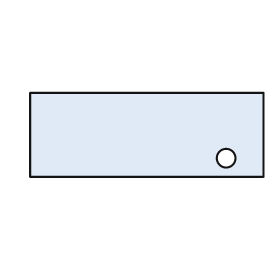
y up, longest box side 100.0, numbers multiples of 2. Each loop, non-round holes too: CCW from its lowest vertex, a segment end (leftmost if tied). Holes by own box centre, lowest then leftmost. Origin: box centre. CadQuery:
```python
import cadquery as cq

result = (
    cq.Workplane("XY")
    .moveTo(-50.0, -18.0)
    .lineTo(50.0, -18.0)
    .lineTo(50.0, 18.0)
    .lineTo(-50.0, 18.0)
    .close()
    .moveTo(34.0, -10.0)
    .circle(4.0)
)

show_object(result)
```